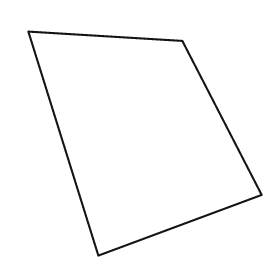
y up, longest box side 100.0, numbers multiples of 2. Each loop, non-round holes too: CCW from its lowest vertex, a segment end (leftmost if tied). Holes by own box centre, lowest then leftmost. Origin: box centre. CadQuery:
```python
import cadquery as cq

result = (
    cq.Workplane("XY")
    .moveTo(-20.0, -48.0)
    .lineTo(50.0, -22.0)
    .lineTo(16.0, 44.0)
    .lineTo(-50.0, 48.0)
    .close()
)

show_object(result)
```